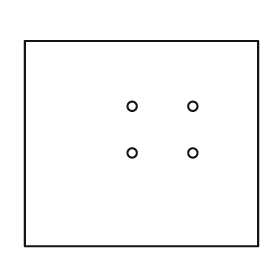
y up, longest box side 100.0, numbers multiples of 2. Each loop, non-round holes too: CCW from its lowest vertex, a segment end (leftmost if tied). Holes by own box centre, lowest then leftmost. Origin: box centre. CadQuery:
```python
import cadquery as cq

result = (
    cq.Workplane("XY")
    .moveTo(-50.0, -44.0)
    .lineTo(50.0, -44.0)
    .lineTo(50.0, 44.0)
    .lineTo(-50.0, 44.0)
    .close()
    .moveTo(-4.0, -4.0)
    .circle(2.0)
    .moveTo(22.0, -4.0)
    .circle(2.0)
    .moveTo(-4.0, 16.0)
    .circle(2.0)
    .moveTo(22.0, 16.0)
    .circle(2.0)
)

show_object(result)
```